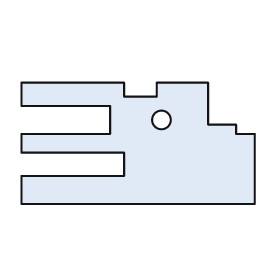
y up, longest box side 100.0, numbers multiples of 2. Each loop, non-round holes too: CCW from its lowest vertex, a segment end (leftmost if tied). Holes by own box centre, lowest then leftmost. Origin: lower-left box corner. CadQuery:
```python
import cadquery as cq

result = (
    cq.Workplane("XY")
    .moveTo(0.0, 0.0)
    .lineTo(100.0, 0.0)
    .lineTo(100.0, 30.0)
    .lineTo(92.0, 30.0)
    .lineTo(92.0, 34.0)
    .lineTo(80.0, 34.0)
    .lineTo(80.0, 52.0)
    .lineTo(58.0, 52.0)
    .lineTo(58.0, 46.0)
    .lineTo(44.0, 46.0)
    .lineTo(44.0, 52.0)
    .lineTo(0.0, 52.0)
    .lineTo(0.0, 42.0)
    .lineTo(38.0, 42.0)
    .lineTo(38.0, 30.0)
    .lineTo(0.0, 30.0)
    .lineTo(0.0, 22.0)
    .lineTo(44.0, 22.0)
    .lineTo(44.0, 12.0)
    .lineTo(0.0, 12.0)
    .close()
    .moveTo(60.0, 36.0)
    .circle(4.0)
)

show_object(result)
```